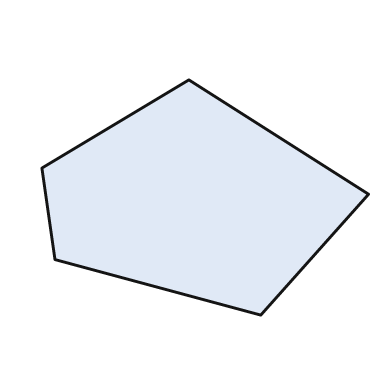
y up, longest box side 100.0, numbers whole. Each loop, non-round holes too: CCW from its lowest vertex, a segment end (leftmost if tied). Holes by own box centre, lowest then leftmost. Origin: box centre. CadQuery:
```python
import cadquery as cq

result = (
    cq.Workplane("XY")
    .moveTo(17.0, -36.0)
    .lineTo(50.0, 1.0)
    .lineTo(-5.0, 36.0)
    .lineTo(-50.0, 9.0)
    .lineTo(-46.0, -19.0)
    .close()
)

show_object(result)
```